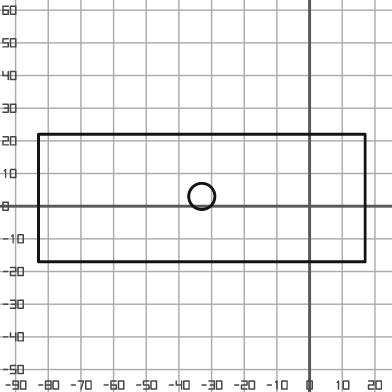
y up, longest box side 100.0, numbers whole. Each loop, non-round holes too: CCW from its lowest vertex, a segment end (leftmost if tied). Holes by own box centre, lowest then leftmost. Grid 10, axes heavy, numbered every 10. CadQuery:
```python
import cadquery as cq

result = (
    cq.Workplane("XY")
    .moveTo(-83.0, -17.0)
    .lineTo(17.0, -17.0)
    .lineTo(17.0, 22.0)
    .lineTo(-83.0, 22.0)
    .close()
    .moveTo(-33.0, 3.0)
    .circle(4.0)
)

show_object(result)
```